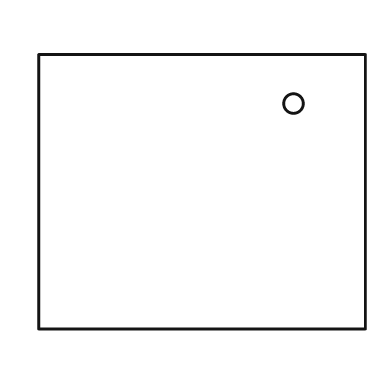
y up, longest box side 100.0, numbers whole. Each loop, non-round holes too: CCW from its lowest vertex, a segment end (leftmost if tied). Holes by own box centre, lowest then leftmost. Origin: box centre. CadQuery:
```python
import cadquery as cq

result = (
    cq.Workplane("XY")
    .moveTo(-50.0, -42.0)
    .lineTo(50.0, -42.0)
    .lineTo(50.0, 42.0)
    .lineTo(-50.0, 42.0)
    .close()
    .moveTo(28.0, 27.0)
    .circle(3.0)
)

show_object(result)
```